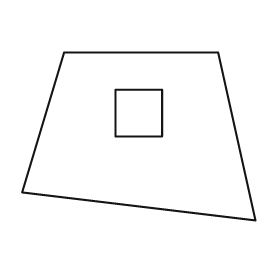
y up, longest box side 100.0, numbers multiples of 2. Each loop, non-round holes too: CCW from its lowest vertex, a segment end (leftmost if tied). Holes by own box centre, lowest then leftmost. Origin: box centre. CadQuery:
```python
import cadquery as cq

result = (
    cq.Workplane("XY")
    .moveTo(50.0, -36.0)
    .lineTo(34.0, 36.0)
    .lineTo(-32.0, 36.0)
    .lineTo(-50.0, -24.0)
    .close()
    .moveTo(-10.0, 0.0)
    .lineTo(10.0, 0.0)
    .lineTo(10.0, 20.0)
    .lineTo(-10.0, 20.0)
    .close()
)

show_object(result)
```